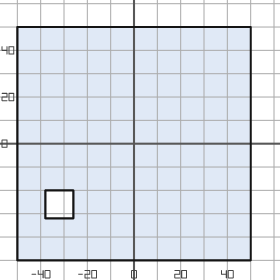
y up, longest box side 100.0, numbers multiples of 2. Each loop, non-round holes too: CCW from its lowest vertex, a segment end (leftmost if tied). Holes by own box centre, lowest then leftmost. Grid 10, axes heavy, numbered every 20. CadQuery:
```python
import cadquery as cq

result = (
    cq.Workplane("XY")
    .moveTo(-50.0, -50.0)
    .lineTo(50.0, -50.0)
    .lineTo(50.0, 50.0)
    .lineTo(-50.0, 50.0)
    .close()
    .moveTo(-38.0, -32.0)
    .lineTo(-26.0, -32.0)
    .lineTo(-26.0, -20.0)
    .lineTo(-38.0, -20.0)
    .close()
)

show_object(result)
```